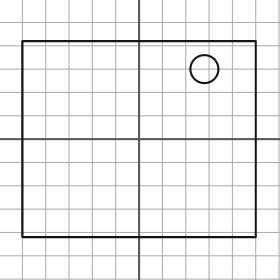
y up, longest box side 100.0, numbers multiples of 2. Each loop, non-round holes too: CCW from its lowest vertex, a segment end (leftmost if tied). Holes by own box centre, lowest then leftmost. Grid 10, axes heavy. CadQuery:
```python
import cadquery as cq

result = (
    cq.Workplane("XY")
    .moveTo(-50.0, -42.0)
    .lineTo(50.0, -42.0)
    .lineTo(50.0, 42.0)
    .lineTo(-50.0, 42.0)
    .close()
    .moveTo(28.0, 30.0)
    .circle(6.0)
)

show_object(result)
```